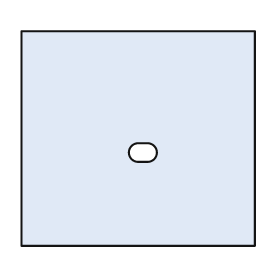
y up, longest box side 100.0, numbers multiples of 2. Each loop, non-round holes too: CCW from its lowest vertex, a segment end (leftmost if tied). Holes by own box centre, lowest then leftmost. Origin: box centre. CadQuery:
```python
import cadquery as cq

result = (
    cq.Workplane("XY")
    .moveTo(-50.0, -46.0)
    .lineTo(50.0, -46.0)
    .lineTo(50.0, 46.0)
    .lineTo(-50.0, 46.0)
    .close()
    .moveTo(0.0, -10.0)
    .lineTo(4.0, -10.0)
    .threePointArc((8.0, -6.0), (4.0, -2.0))
    .lineTo(0.0, -2.0)
    .threePointArc((-4.0, -6.0), (0.0, -10.0))
    .close()
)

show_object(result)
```